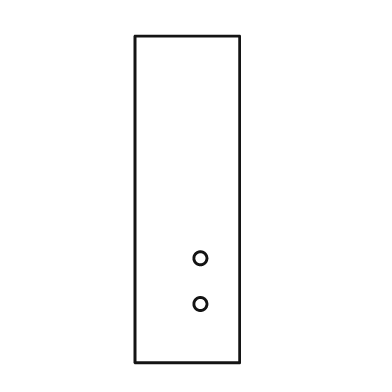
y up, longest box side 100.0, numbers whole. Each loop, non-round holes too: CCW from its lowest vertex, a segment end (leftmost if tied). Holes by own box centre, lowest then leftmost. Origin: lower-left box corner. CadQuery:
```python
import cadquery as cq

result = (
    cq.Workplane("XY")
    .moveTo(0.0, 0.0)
    .lineTo(32.0, 0.0)
    .lineTo(32.0, 100.0)
    .lineTo(0.0, 100.0)
    .close()
    .moveTo(20.0, 18.0)
    .circle(2.0)
    .moveTo(20.0, 32.0)
    .circle(2.0)
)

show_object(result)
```